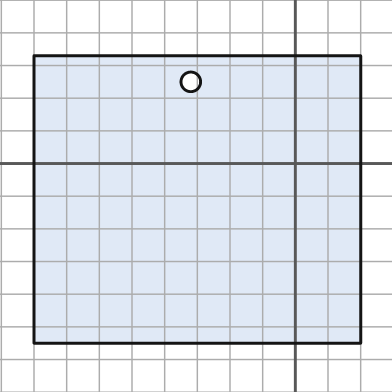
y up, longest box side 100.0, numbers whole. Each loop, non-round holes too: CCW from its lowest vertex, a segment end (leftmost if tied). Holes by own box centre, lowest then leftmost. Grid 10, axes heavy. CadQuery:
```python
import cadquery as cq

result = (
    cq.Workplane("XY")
    .moveTo(-80.0, -55.0)
    .lineTo(20.0, -55.0)
    .lineTo(20.0, 33.0)
    .lineTo(-80.0, 33.0)
    .close()
    .moveTo(-32.0, 25.0)
    .circle(3.0)
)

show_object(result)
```